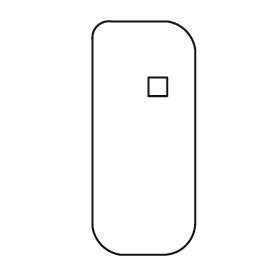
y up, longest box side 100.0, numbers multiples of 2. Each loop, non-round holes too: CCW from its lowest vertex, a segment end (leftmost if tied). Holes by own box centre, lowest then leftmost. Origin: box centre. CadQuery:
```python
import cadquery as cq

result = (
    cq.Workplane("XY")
    .moveTo(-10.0, -50.0)
    .lineTo(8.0, -50.0)
    .threePointArc((18.0, -46.0), (22.0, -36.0))
    .lineTo(22.0, 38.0)
    .threePointArc((18.0, 46.0), (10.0, 50.0))
    .lineTo(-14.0, 50.0)
    .threePointArc((-20.0, 48.0), (-22.0, 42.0))
    .lineTo(-22.0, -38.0)
    .threePointArc((-18.0, -46.0), (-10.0, -50.0))
    .close()
    .moveTo(2.0, 18.0)
    .lineTo(10.0, 18.0)
    .lineTo(10.0, 26.0)
    .lineTo(2.0, 26.0)
    .close()
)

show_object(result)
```